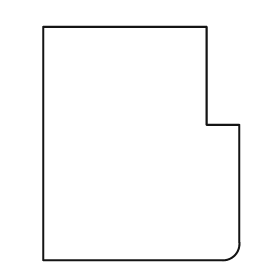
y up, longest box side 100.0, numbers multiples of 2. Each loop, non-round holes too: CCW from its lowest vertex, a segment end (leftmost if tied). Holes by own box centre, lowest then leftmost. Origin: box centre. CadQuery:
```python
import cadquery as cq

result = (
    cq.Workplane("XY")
    .moveTo(-42.0, -50.0)
    .lineTo(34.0, -50.0)
    .threePointArc((40.0, -48.0), (42.0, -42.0))
    .lineTo(42.0, 8.0)
    .lineTo(28.0, 8.0)
    .lineTo(28.0, 50.0)
    .lineTo(-42.0, 50.0)
    .close()
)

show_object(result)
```